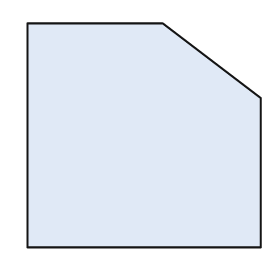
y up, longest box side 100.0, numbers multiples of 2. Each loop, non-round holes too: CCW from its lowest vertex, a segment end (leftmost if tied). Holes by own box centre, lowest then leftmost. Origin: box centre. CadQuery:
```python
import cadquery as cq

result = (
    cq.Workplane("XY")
    .moveTo(-50.0, -48.0)
    .lineTo(50.0, -48.0)
    .lineTo(50.0, 16.0)
    .lineTo(8.0, 48.0)
    .lineTo(-50.0, 48.0)
    .close()
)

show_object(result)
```